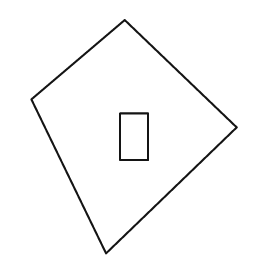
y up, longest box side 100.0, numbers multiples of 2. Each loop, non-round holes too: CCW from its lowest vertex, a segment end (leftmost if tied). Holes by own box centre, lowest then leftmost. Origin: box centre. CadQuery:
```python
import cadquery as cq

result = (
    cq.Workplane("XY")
    .moveTo(-12.0, -50.0)
    .lineTo(44.0, 4.0)
    .lineTo(-4.0, 50.0)
    .lineTo(-44.0, 16.0)
    .close()
    .moveTo(-6.0, -10.0)
    .lineTo(6.0, -10.0)
    .lineTo(6.0, 10.0)
    .lineTo(-6.0, 10.0)
    .close()
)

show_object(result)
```